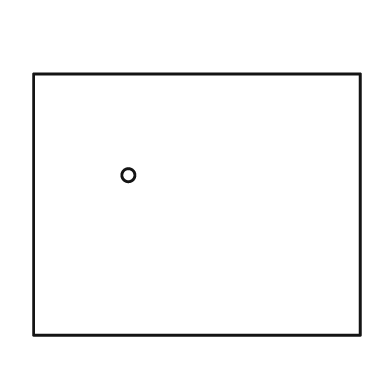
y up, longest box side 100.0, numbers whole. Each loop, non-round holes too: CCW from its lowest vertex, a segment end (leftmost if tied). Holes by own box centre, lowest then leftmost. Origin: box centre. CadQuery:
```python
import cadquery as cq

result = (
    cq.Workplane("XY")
    .moveTo(-50.0, -40.0)
    .lineTo(50.0, -40.0)
    .lineTo(50.0, 40.0)
    .lineTo(-50.0, 40.0)
    .close()
    .moveTo(-21.0, 9.0)
    .circle(2.0)
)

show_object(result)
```